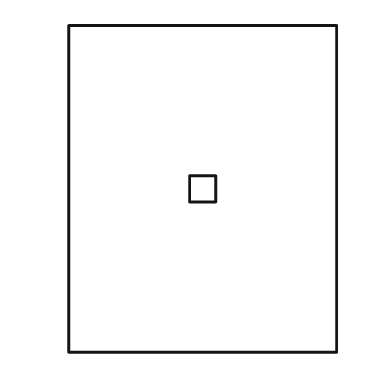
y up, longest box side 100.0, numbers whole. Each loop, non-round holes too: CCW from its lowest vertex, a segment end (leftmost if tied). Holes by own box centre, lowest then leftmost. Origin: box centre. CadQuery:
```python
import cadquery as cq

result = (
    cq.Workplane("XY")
    .moveTo(-41.0, -50.0)
    .lineTo(41.0, -50.0)
    .lineTo(41.0, 50.0)
    .lineTo(-41.0, 50.0)
    .close()
    .moveTo(-4.0, -4.0)
    .lineTo(4.0, -4.0)
    .lineTo(4.0, 4.0)
    .lineTo(-4.0, 4.0)
    .close()
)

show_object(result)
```